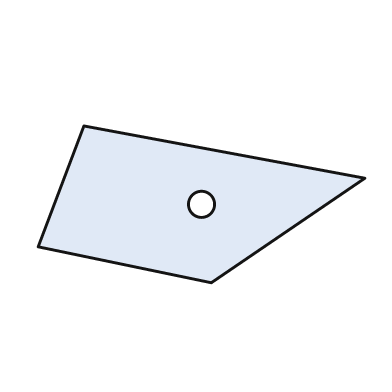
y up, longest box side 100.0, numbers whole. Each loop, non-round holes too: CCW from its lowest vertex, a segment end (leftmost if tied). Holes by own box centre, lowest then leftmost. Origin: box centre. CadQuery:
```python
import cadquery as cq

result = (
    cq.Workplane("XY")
    .moveTo(3.0, -24.0)
    .lineTo(50.0, 8.0)
    .lineTo(-36.0, 24.0)
    .lineTo(-50.0, -13.0)
    .close()
    .moveTo(0.0, 0.0)
    .circle(4.0)
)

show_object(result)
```